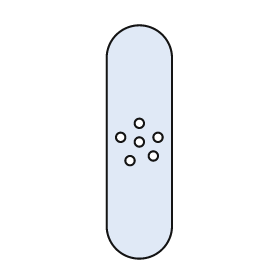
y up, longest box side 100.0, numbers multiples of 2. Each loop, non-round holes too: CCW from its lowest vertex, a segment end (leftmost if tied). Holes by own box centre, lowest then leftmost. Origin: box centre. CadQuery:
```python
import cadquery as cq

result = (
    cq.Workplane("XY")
    .moveTo(-14.0, -36.0)
    .threePointArc((0.0, -50.0), (14.0, -36.0))
    .lineTo(14.0, 36.0)
    .threePointArc((0.0, 50.0), (-14.0, 36.0))
    .close()
    .moveTo(-4.0, -8.0)
    .circle(2.0)
    .moveTo(6.0, -6.0)
    .circle(2.0)
    .moveTo(0.0, 0.0)
    .circle(2.0)
    .moveTo(-8.0, 2.0)
    .circle(2.0)
    .moveTo(8.0, 2.0)
    .circle(2.0)
    .moveTo(0.0, 8.0)
    .circle(2.0)
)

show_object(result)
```